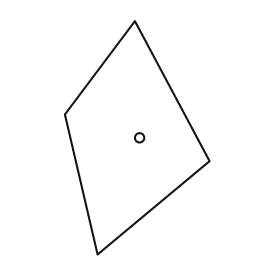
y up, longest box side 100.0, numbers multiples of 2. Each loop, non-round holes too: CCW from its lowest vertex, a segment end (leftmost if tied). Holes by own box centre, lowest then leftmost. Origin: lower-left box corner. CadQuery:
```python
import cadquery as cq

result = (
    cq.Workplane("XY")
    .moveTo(14.0, 0.0)
    .lineTo(62.0, 40.0)
    .lineTo(30.0, 100.0)
    .lineTo(0.0, 60.0)
    .close()
    .moveTo(32.0, 50.0)
    .circle(2.0)
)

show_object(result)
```